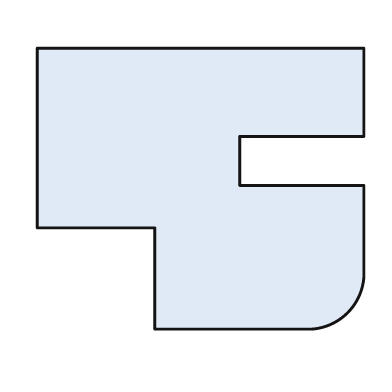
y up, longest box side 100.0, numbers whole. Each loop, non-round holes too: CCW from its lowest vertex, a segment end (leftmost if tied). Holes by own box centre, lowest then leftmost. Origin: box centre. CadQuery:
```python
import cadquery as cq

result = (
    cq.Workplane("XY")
    .moveTo(-14.0, -43.0)
    .lineTo(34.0, -43.0)
    .threePointArc((45.0, -38.0), (50.0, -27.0))
    .lineTo(50.0, 1.0)
    .lineTo(12.0, 1.0)
    .lineTo(12.0, 16.0)
    .lineTo(50.0, 16.0)
    .lineTo(50.0, 43.0)
    .lineTo(-50.0, 43.0)
    .lineTo(-50.0, -12.0)
    .lineTo(-14.0, -12.0)
    .close()
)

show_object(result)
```